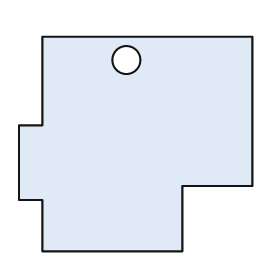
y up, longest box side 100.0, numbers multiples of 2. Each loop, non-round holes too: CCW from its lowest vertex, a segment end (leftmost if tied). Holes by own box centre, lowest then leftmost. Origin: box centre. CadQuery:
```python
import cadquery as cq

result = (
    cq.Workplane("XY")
    .moveTo(-40.0, -46.0)
    .lineTo(20.0, -46.0)
    .lineTo(20.0, -18.0)
    .lineTo(50.0, -18.0)
    .lineTo(50.0, 46.0)
    .lineTo(-40.0, 46.0)
    .lineTo(-40.0, 8.0)
    .lineTo(-50.0, 8.0)
    .lineTo(-50.0, -24.0)
    .lineTo(-40.0, -24.0)
    .close()
    .moveTo(-4.0, 36.0)
    .circle(6.0)
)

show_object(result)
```